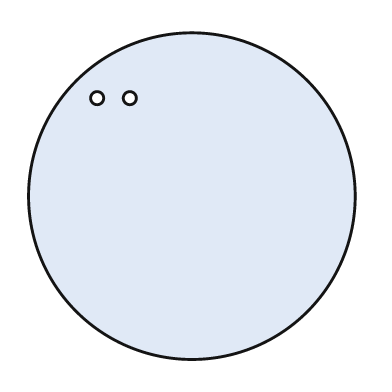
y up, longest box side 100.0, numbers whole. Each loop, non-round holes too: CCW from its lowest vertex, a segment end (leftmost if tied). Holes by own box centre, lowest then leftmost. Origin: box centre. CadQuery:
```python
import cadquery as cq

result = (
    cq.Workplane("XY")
    .moveTo(0.0, 0.0)
    .circle(50.0)
    .moveTo(-29.0, 30.0)
    .circle(2.0)
    .moveTo(-19.0, 30.0)
    .circle(2.0)
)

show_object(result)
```